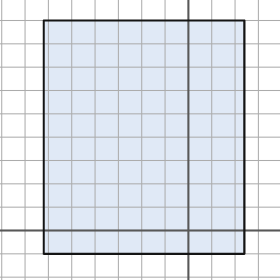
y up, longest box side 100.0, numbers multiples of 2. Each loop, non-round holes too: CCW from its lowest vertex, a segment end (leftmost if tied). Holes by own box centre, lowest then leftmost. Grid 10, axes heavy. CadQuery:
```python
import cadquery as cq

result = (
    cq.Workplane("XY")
    .moveTo(-62.0, -10.0)
    .lineTo(24.0, -10.0)
    .lineTo(24.0, 90.0)
    .lineTo(-62.0, 90.0)
    .close()
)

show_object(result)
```